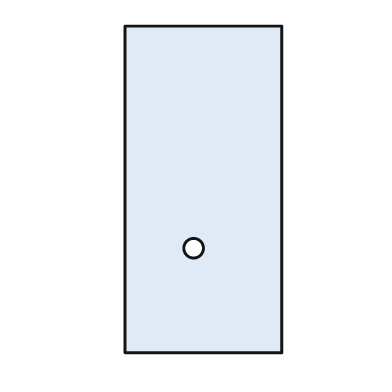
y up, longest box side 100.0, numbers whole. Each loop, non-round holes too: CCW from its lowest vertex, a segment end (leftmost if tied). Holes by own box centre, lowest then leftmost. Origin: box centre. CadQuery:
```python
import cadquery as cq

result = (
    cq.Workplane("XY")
    .moveTo(-24.0, -50.0)
    .lineTo(24.0, -50.0)
    .lineTo(24.0, 50.0)
    .lineTo(-24.0, 50.0)
    .close()
    .moveTo(-3.0, -18.0)
    .circle(3.0)
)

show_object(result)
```